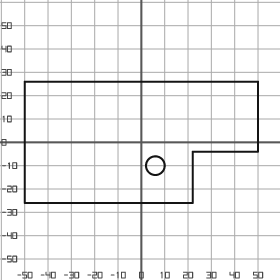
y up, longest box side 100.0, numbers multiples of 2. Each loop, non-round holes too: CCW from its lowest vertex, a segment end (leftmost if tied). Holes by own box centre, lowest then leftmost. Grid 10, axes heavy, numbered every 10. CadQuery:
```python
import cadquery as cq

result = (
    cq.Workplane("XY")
    .moveTo(-50.0, -26.0)
    .lineTo(22.0, -26.0)
    .lineTo(22.0, -4.0)
    .lineTo(50.0, -4.0)
    .lineTo(50.0, 26.0)
    .lineTo(-50.0, 26.0)
    .close()
    .moveTo(6.0, -10.0)
    .circle(4.0)
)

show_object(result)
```